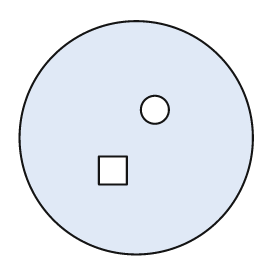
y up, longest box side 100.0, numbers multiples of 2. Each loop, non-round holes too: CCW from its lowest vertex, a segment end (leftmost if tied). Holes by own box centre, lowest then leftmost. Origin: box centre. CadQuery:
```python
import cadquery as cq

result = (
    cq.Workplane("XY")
    .moveTo(0.0, 0.0)
    .circle(50.0)
    .moveTo(-16.0, -20.0)
    .lineTo(-4.0, -20.0)
    .lineTo(-4.0, -8.0)
    .lineTo(-16.0, -8.0)
    .close()
    .moveTo(8.0, 12.0)
    .circle(6.0)
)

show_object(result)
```